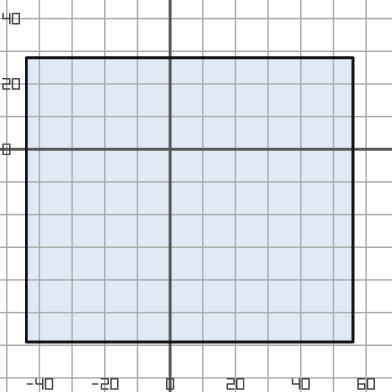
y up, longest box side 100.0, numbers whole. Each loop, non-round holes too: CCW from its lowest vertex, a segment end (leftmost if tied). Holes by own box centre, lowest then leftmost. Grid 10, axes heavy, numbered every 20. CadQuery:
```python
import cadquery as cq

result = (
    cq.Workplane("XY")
    .moveTo(-44.0, -59.0)
    .lineTo(56.0, -59.0)
    .lineTo(56.0, 28.0)
    .lineTo(-44.0, 28.0)
    .close()
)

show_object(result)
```